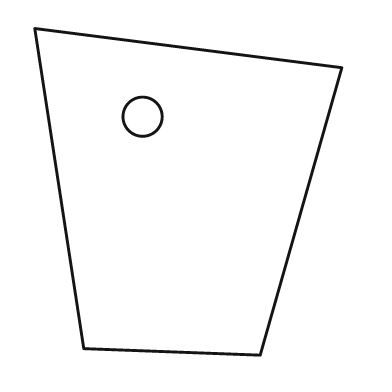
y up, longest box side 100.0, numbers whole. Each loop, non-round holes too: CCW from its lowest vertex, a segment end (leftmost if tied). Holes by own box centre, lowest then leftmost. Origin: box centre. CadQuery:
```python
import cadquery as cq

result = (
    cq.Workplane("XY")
    .moveTo(22.0, -50.0)
    .lineTo(47.0, 38.0)
    .lineTo(-47.0, 50.0)
    .lineTo(-32.0, -48.0)
    .close()
    .moveTo(-14.0, 23.0)
    .circle(6.0)
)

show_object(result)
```